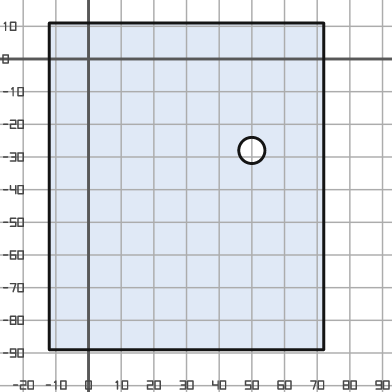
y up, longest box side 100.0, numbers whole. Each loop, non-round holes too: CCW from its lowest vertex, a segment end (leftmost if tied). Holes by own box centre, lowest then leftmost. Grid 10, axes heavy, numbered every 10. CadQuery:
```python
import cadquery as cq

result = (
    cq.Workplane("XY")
    .moveTo(-12.0, -89.0)
    .lineTo(72.0, -89.0)
    .lineTo(72.0, 11.0)
    .lineTo(-12.0, 11.0)
    .close()
    .moveTo(50.0, -28.0)
    .circle(4.0)
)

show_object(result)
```